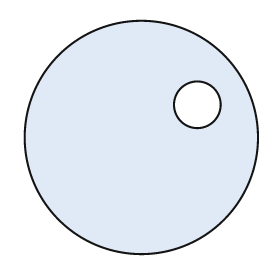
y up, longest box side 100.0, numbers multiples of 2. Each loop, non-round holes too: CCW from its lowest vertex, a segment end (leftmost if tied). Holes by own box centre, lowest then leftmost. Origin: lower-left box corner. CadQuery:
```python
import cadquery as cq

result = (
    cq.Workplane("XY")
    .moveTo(50.0, 50.0)
    .circle(50.0)
    .moveTo(74.0, 64.0)
    .circle(10.0)
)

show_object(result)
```